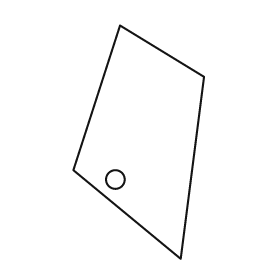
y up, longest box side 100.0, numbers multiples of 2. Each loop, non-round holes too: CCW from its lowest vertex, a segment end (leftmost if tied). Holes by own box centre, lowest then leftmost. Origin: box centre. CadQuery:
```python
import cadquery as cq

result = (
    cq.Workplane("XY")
    .moveTo(18.0, -50.0)
    .lineTo(28.0, 28.0)
    .lineTo(-8.0, 50.0)
    .lineTo(-28.0, -12.0)
    .close()
    .moveTo(-10.0, -16.0)
    .circle(4.0)
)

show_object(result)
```